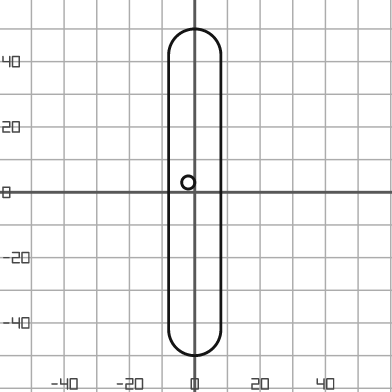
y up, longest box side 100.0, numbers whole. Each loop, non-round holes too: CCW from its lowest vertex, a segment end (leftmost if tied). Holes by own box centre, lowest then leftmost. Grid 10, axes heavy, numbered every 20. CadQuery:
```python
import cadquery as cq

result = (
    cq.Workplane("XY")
    .moveTo(-8.0, -42.0)
    .threePointArc((0.0, -50.0), (8.0, -42.0))
    .lineTo(8.0, 42.0)
    .threePointArc((0.0, 50.0), (-8.0, 42.0))
    .close()
    .moveTo(-2.0, 3.0)
    .circle(2.0)
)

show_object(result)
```